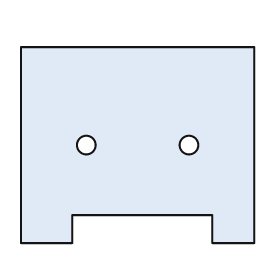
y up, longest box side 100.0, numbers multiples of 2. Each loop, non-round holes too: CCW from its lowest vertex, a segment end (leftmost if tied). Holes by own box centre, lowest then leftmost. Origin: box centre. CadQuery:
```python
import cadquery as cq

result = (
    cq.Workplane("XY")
    .moveTo(-50.0, -42.0)
    .lineTo(-28.0, -42.0)
    .lineTo(-28.0, -30.0)
    .lineTo(32.0, -30.0)
    .lineTo(32.0, -42.0)
    .lineTo(50.0, -42.0)
    .lineTo(50.0, 42.0)
    .lineTo(-50.0, 42.0)
    .close()
    .moveTo(-22.0, 0.0)
    .circle(4.0)
    .moveTo(22.0, 0.0)
    .circle(4.0)
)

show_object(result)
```